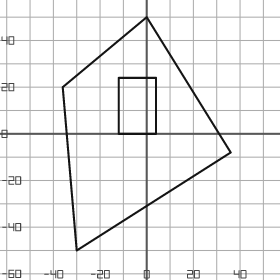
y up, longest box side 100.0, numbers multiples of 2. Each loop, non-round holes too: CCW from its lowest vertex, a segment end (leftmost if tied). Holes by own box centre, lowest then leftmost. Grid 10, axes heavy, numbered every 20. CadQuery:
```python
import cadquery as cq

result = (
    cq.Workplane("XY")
    .moveTo(-30.0, -50.0)
    .lineTo(36.0, -8.0)
    .lineTo(0.0, 50.0)
    .lineTo(-36.0, 20.0)
    .close()
    .moveTo(-12.0, 0.0)
    .lineTo(4.0, 0.0)
    .lineTo(4.0, 24.0)
    .lineTo(-12.0, 24.0)
    .close()
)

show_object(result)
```